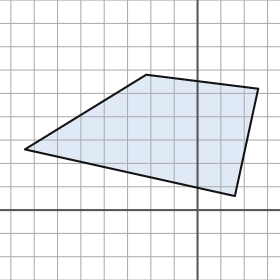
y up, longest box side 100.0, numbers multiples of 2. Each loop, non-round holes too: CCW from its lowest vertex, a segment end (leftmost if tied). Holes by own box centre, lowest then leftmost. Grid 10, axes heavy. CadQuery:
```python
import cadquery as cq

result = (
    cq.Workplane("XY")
    .moveTo(16.0, 6.0)
    .lineTo(26.0, 52.0)
    .lineTo(-22.0, 58.0)
    .lineTo(-74.0, 26.0)
    .close()
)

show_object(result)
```